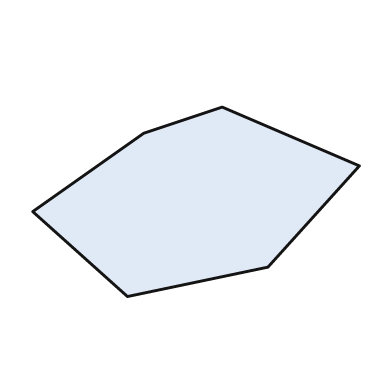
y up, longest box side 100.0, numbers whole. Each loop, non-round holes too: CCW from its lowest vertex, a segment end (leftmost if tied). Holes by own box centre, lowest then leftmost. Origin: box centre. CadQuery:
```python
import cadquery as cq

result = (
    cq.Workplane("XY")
    .moveTo(-21.0, -29.0)
    .lineTo(22.0, -20.0)
    .lineTo(50.0, 11.0)
    .lineTo(8.0, 29.0)
    .lineTo(-16.0, 21.0)
    .lineTo(-50.0, -3.0)
    .close()
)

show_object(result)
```